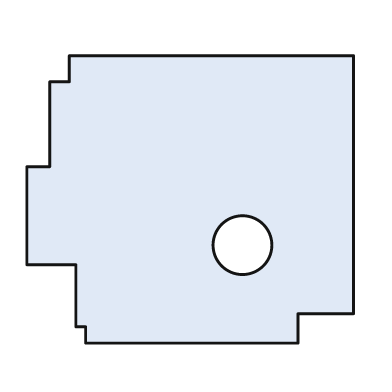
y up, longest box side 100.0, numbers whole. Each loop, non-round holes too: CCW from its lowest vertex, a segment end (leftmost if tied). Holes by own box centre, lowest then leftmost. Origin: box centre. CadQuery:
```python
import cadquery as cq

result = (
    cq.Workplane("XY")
    .moveTo(-32.0, -44.0)
    .lineTo(33.0, -44.0)
    .lineTo(33.0, -35.0)
    .lineTo(50.0, -35.0)
    .lineTo(50.0, 44.0)
    .lineTo(-37.0, 44.0)
    .lineTo(-37.0, 36.0)
    .lineTo(-43.0, 36.0)
    .lineTo(-43.0, 10.0)
    .lineTo(-50.0, 10.0)
    .lineTo(-50.0, -20.0)
    .lineTo(-35.0, -20.0)
    .lineTo(-35.0, -39.0)
    .lineTo(-32.0, -39.0)
    .close()
    .moveTo(16.0, -14.0)
    .circle(9.0)
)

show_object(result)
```